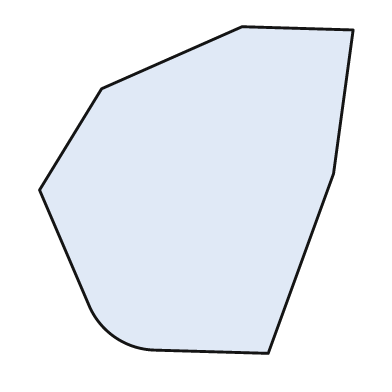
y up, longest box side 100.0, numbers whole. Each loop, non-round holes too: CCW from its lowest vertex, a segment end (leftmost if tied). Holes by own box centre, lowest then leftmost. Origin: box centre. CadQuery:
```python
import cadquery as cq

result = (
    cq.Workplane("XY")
    .moveTo(22.0, -50.0)
    .lineTo(42.0, 5.0)
    .lineTo(48.0, 49.0)
    .lineTo(14.0, 50.0)
    .lineTo(-29.0, 31.0)
    .lineTo(-48.0, 0.0)
    .lineTo(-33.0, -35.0)
    .threePointArc((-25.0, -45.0), (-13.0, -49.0))
    .close()
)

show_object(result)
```